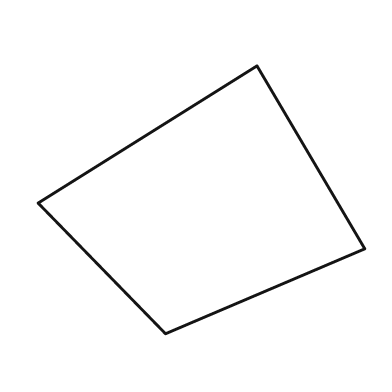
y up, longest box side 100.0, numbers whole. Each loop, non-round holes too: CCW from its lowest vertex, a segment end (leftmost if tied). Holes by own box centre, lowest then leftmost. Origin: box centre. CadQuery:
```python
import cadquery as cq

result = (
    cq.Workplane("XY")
    .moveTo(-11.0, -41.0)
    .lineTo(50.0, -15.0)
    .lineTo(17.0, 41.0)
    .lineTo(-50.0, -1.0)
    .close()
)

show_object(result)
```